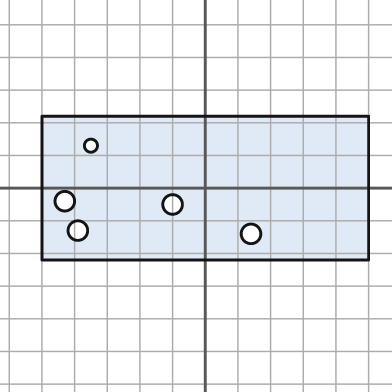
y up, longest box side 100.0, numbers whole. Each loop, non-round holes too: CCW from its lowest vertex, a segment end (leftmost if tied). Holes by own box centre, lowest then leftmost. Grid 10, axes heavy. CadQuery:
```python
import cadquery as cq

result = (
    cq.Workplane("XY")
    .moveTo(-50.0, -22.0)
    .lineTo(50.0, -22.0)
    .lineTo(50.0, 22.0)
    .lineTo(-50.0, 22.0)
    .close()
    .moveTo(14.0, -14.0)
    .circle(3.0)
    .moveTo(-39.0, -13.0)
    .circle(3.0)
    .moveTo(-10.0, -5.0)
    .circle(3.0)
    .moveTo(-43.0, -4.0)
    .circle(3.0)
    .moveTo(-35.0, 13.0)
    .circle(2.0)
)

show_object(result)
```